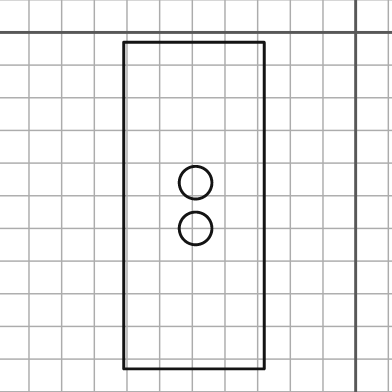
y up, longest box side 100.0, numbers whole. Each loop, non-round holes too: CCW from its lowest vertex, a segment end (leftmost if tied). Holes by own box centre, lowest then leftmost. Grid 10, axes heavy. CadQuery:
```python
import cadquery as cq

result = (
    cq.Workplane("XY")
    .moveTo(-71.0, -103.0)
    .lineTo(-28.0, -103.0)
    .lineTo(-28.0, -3.0)
    .lineTo(-71.0, -3.0)
    .close()
    .moveTo(-49.0, -60.0)
    .circle(5.0)
    .moveTo(-49.0, -46.0)
    .circle(5.0)
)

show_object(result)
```